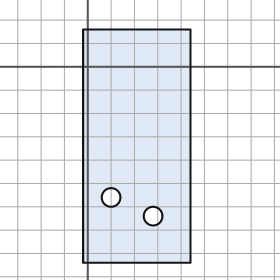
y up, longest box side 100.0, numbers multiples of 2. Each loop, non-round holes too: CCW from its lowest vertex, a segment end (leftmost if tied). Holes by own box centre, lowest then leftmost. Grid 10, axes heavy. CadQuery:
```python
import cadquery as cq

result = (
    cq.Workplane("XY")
    .moveTo(-2.0, -84.0)
    .lineTo(44.0, -84.0)
    .lineTo(44.0, 16.0)
    .lineTo(-2.0, 16.0)
    .close()
    .moveTo(28.0, -64.0)
    .circle(4.0)
    .moveTo(10.0, -56.0)
    .circle(4.0)
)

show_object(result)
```